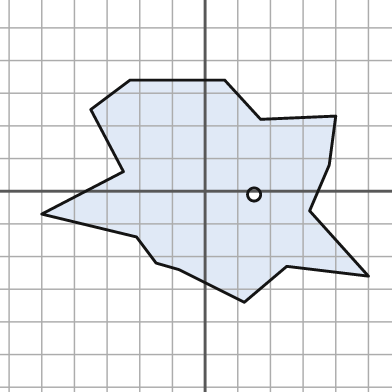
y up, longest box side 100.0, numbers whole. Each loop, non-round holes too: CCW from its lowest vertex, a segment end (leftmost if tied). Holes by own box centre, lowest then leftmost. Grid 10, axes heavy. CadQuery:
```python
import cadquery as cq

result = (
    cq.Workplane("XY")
    .moveTo(12.0, -34.0)
    .lineTo(25.0, -23.0)
    .lineTo(50.0, -26.0)
    .lineTo(32.0, -6.0)
    .lineTo(38.0, 8.0)
    .lineTo(40.0, 23.0)
    .lineTo(17.0, 22.0)
    .lineTo(6.0, 34.0)
    .lineTo(-23.0, 34.0)
    .lineTo(-35.0, 25.0)
    .lineTo(-25.0, 6.0)
    .lineTo(-50.0, -7.0)
    .lineTo(-21.0, -14.0)
    .lineTo(-15.0, -22.0)
    .lineTo(-8.0, -24.0)
    .close()
    .moveTo(15.0, -1.0)
    .circle(2.0)
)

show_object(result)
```